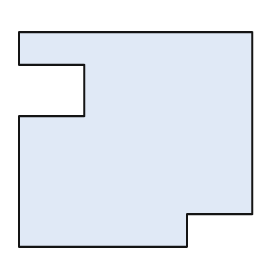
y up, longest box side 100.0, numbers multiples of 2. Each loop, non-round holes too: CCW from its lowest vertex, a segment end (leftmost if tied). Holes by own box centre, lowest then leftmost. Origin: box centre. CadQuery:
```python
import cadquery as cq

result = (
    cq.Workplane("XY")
    .moveTo(-50.0, -46.0)
    .lineTo(22.0, -46.0)
    .lineTo(22.0, -32.0)
    .lineTo(50.0, -32.0)
    .lineTo(50.0, 46.0)
    .lineTo(-50.0, 46.0)
    .lineTo(-50.0, 32.0)
    .lineTo(-22.0, 32.0)
    .lineTo(-22.0, 10.0)
    .lineTo(-50.0, 10.0)
    .close()
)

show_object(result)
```